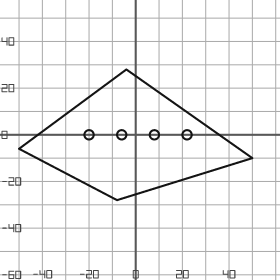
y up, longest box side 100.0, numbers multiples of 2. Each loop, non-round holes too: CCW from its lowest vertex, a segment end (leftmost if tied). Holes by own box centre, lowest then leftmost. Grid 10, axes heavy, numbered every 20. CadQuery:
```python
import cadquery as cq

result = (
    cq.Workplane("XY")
    .moveTo(-8.0, -28.0)
    .lineTo(50.0, -10.0)
    .lineTo(-4.0, 28.0)
    .lineTo(-50.0, -6.0)
    .close()
    .moveTo(-20.0, 0.0)
    .circle(2.0)
    .moveTo(-6.0, 0.0)
    .circle(2.0)
    .moveTo(8.0, 0.0)
    .circle(2.0)
    .moveTo(22.0, 0.0)
    .circle(2.0)
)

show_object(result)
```